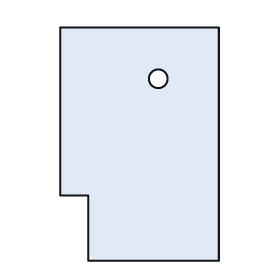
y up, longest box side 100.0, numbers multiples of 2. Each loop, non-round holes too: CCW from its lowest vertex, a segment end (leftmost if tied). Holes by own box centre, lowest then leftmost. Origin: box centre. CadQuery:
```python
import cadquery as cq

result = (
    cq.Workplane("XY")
    .moveTo(-22.0, -50.0)
    .lineTo(34.0, -50.0)
    .lineTo(34.0, 50.0)
    .lineTo(-34.0, 50.0)
    .lineTo(-34.0, -22.0)
    .lineTo(-22.0, -22.0)
    .close()
    .moveTo(8.0, 28.0)
    .circle(4.0)
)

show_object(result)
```